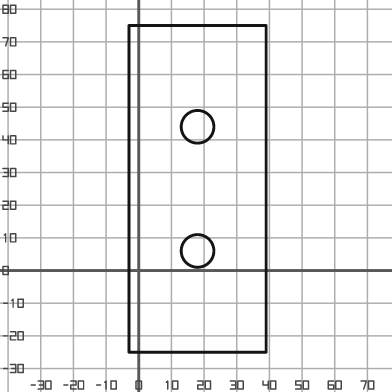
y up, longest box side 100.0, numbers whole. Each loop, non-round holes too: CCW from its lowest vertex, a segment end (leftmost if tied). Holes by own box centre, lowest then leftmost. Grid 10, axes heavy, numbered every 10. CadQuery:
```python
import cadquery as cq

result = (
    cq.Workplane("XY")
    .moveTo(-3.0, -25.0)
    .lineTo(39.0, -25.0)
    .lineTo(39.0, 75.0)
    .lineTo(-3.0, 75.0)
    .close()
    .moveTo(18.0, 6.0)
    .circle(5.0)
    .moveTo(18.0, 44.0)
    .circle(5.0)
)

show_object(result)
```